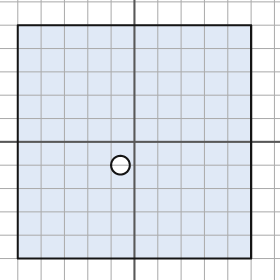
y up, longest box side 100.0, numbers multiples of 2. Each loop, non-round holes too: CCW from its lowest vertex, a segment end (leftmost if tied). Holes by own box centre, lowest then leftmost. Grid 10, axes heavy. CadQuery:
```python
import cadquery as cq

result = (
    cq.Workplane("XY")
    .moveTo(-50.0, -50.0)
    .lineTo(50.0, -50.0)
    .lineTo(50.0, 50.0)
    .lineTo(-50.0, 50.0)
    .close()
    .moveTo(-6.0, -10.0)
    .circle(4.0)
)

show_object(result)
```